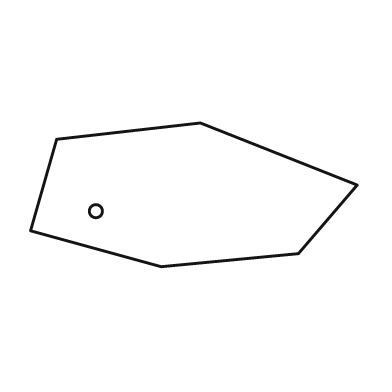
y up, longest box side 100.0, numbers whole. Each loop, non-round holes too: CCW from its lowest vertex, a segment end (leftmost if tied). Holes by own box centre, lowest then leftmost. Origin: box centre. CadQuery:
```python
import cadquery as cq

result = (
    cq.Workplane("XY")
    .moveTo(-10.0, -22.0)
    .lineTo(32.0, -18.0)
    .lineTo(50.0, 3.0)
    .lineTo(2.0, 22.0)
    .lineTo(-42.0, 17.0)
    .lineTo(-50.0, -11.0)
    .close()
    .moveTo(-30.0, -5.0)
    .circle(2.0)
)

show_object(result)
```